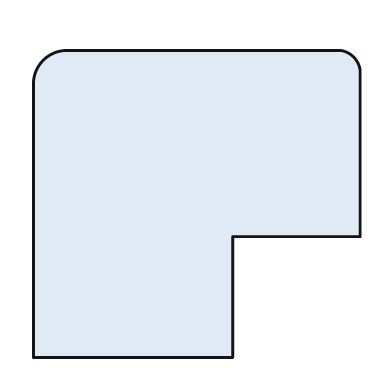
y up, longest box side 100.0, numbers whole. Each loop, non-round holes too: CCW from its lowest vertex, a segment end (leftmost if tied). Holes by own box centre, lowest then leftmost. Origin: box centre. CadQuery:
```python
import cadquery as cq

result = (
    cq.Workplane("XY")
    .moveTo(-50.0, -47.0)
    .lineTo(11.0, -47.0)
    .lineTo(11.0, -10.0)
    .lineTo(50.0, -10.0)
    .lineTo(50.0, 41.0)
    .threePointArc((48.0, 45.0), (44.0, 47.0))
    .lineTo(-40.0, 47.0)
    .threePointArc((-47.0, 44.0), (-50.0, 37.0))
    .close()
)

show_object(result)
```